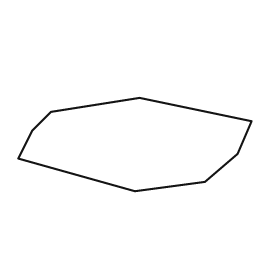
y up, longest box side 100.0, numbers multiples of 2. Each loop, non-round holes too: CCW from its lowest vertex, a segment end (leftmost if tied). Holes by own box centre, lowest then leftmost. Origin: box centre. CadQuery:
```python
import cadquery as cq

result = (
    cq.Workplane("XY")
    .moveTo(0.0, -20.0)
    .lineTo(30.0, -16.0)
    .lineTo(44.0, -4.0)
    .lineTo(50.0, 10.0)
    .lineTo(2.0, 20.0)
    .lineTo(-36.0, 14.0)
    .lineTo(-44.0, 6.0)
    .lineTo(-50.0, -6.0)
    .close()
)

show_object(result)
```